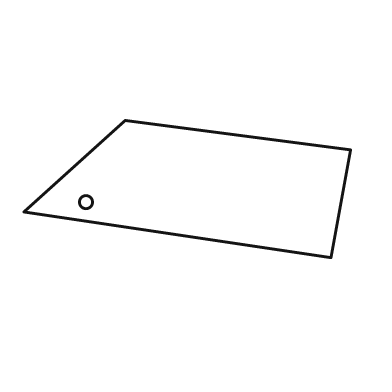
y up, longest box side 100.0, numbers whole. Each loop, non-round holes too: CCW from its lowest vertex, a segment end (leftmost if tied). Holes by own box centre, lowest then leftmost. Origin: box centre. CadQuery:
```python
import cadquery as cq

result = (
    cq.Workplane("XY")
    .moveTo(44.0, -21.0)
    .lineTo(50.0, 12.0)
    .lineTo(-19.0, 21.0)
    .lineTo(-50.0, -7.0)
    .close()
    .moveTo(-31.0, -4.0)
    .circle(2.0)
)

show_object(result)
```